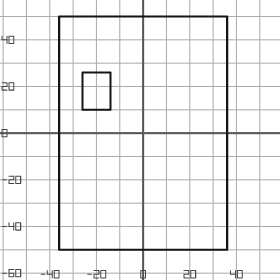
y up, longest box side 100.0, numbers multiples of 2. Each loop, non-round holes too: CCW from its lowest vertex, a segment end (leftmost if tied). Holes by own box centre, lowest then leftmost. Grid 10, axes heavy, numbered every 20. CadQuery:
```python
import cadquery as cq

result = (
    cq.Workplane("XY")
    .moveTo(-36.0, -50.0)
    .lineTo(36.0, -50.0)
    .lineTo(36.0, 50.0)
    .lineTo(-36.0, 50.0)
    .close()
    .moveTo(-26.0, 10.0)
    .lineTo(-14.0, 10.0)
    .lineTo(-14.0, 26.0)
    .lineTo(-26.0, 26.0)
    .close()
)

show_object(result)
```